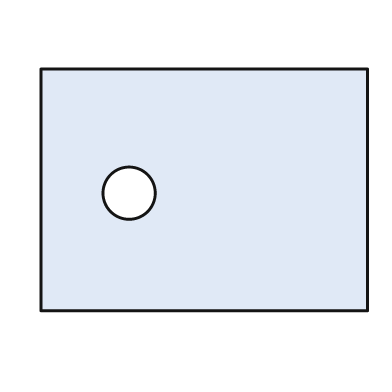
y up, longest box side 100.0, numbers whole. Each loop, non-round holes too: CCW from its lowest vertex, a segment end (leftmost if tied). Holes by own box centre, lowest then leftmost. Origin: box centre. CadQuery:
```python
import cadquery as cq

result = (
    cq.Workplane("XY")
    .moveTo(-50.0, -37.0)
    .lineTo(50.0, -37.0)
    .lineTo(50.0, 37.0)
    .lineTo(-50.0, 37.0)
    .close()
    .moveTo(-23.0, -1.0)
    .circle(8.0)
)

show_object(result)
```